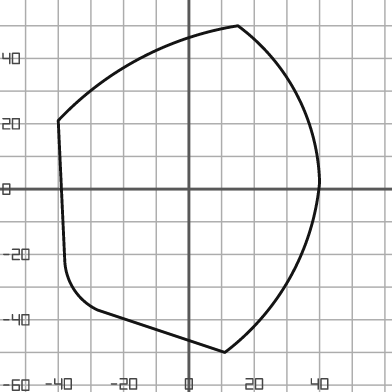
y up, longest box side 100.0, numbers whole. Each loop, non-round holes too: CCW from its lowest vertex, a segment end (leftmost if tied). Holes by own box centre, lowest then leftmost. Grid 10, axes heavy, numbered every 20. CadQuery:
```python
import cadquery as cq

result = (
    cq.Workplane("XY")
    .moveTo(11.0, -50.0)
    .threePointArc((31.0, -27.0), (40.0, 2.0))
    .threePointArc((33.0, 29.0), (15.0, 50.0))
    .threePointArc((-15.0, 40.0), (-40.0, 21.0))
    .lineTo(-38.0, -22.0)
    .threePointArc((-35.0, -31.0), (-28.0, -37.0))
    .close()
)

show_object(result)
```